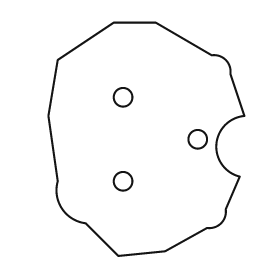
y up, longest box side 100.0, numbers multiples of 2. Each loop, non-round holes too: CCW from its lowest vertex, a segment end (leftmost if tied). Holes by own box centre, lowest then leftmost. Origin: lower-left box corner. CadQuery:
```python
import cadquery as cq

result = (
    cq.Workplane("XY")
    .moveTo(30.0, 0.0)
    .lineTo(50.0, 2.0)
    .lineTo(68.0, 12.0)
    .threePointArc((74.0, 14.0), (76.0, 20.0))
    .lineTo(82.0, 34.0)
    .threePointArc((72.0, 48.0), (84.0, 60.0))
    .lineTo(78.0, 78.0)
    .threePointArc((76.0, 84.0), (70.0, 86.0))
    .lineTo(46.0, 100.0)
    .lineTo(28.0, 100.0)
    .lineTo(4.0, 84.0)
    .lineTo(0.0, 60.0)
    .lineTo(4.0, 32.0)
    .threePointArc((6.0, 20.0), (16.0, 14.0))
    .close()
    .moveTo(32.0, 32.0)
    .circle(4.0)
    .moveTo(64.0, 50.0)
    .circle(4.0)
    .moveTo(32.0, 68.0)
    .circle(4.0)
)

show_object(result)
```